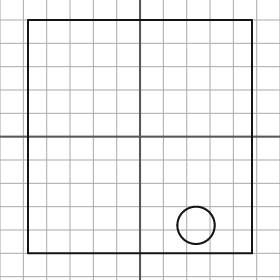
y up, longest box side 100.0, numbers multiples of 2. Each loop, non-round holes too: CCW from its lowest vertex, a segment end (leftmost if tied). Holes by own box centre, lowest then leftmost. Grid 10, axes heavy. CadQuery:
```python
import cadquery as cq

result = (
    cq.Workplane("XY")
    .moveTo(-48.0, -50.0)
    .lineTo(48.0, -50.0)
    .lineTo(48.0, 50.0)
    .lineTo(-48.0, 50.0)
    .close()
    .moveTo(24.0, -38.0)
    .circle(8.0)
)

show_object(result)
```